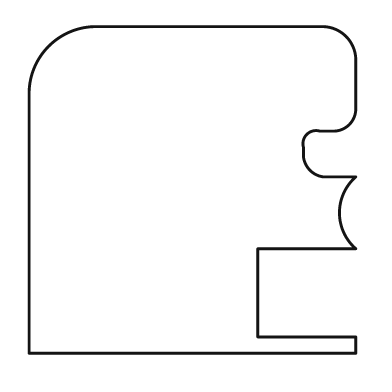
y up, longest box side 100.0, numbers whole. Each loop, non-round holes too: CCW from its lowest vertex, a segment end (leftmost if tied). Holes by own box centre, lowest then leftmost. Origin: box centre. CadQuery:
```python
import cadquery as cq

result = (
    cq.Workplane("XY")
    .moveTo(-50.0, -50.0)
    .lineTo(50.0, -50.0)
    .lineTo(50.0, -45.0)
    .lineTo(20.0, -45.0)
    .lineTo(20.0, -18.0)
    .lineTo(50.0, -18.0)
    .threePointArc((45.0, -7.0), (50.0, 4.0))
    .lineTo(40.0, 4.0)
    .threePointArc((36.0, 6.0), (34.0, 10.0))
    .lineTo(34.0, 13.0)
    .threePointArc((35.0, 17.0), (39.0, 18.0))
    .lineTo(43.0, 18.0)
    .threePointArc((48.0, 20.0), (50.0, 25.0))
    .lineTo(50.0, 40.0)
    .threePointArc((47.0, 47.0), (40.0, 50.0))
    .lineTo(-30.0, 50.0)
    .threePointArc((-44.0, 44.0), (-50.0, 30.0))
    .close()
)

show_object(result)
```